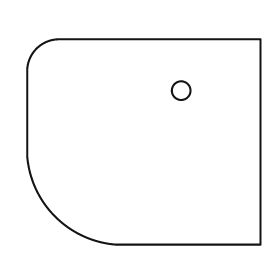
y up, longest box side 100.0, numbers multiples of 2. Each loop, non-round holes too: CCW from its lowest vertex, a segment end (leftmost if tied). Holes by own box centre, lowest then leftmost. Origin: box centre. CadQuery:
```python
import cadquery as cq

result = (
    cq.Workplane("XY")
    .moveTo(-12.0, -44.0)
    .lineTo(50.0, -44.0)
    .lineTo(50.0, 44.0)
    .lineTo(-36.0, 44.0)
    .threePointArc((-46.0, 40.0), (-50.0, 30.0))
    .lineTo(-50.0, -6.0)
    .threePointArc((-38.0, -32.0), (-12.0, -44.0))
    .close()
    .moveTo(16.0, 22.0)
    .circle(4.0)
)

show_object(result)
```